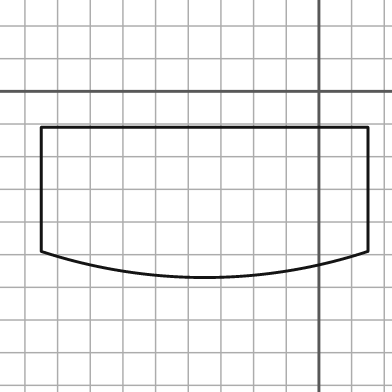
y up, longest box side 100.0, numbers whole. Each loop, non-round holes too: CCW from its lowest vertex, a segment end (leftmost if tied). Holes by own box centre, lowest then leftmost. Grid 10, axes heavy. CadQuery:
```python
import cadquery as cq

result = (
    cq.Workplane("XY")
    .moveTo(-85.0, -49.0)
    .threePointArc((-35.0, -57.0), (15.0, -49.0))
    .lineTo(15.0, -11.0)
    .lineTo(-85.0, -11.0)
    .close()
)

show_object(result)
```